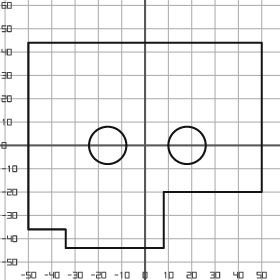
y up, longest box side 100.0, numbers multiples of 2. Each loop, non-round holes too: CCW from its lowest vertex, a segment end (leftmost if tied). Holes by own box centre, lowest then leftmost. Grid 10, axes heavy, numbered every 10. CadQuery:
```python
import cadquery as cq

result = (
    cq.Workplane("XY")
    .moveTo(-34.0, -44.0)
    .lineTo(8.0, -44.0)
    .lineTo(8.0, -20.0)
    .lineTo(50.0, -20.0)
    .lineTo(50.0, 44.0)
    .lineTo(-50.0, 44.0)
    .lineTo(-50.0, -36.0)
    .lineTo(-34.0, -36.0)
    .close()
    .moveTo(-16.0, 0.0)
    .circle(8.0)
    .moveTo(18.0, 0.0)
    .circle(8.0)
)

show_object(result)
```